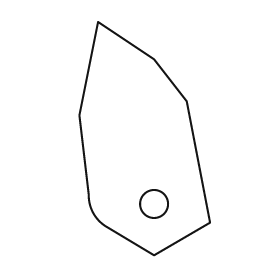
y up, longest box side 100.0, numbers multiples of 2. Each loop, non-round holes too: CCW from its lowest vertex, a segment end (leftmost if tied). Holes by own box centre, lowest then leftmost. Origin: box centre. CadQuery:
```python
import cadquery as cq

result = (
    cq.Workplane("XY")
    .moveTo(4.0, -50.0)
    .lineTo(28.0, -36.0)
    .lineTo(18.0, 16.0)
    .lineTo(4.0, 34.0)
    .lineTo(-20.0, 50.0)
    .lineTo(-28.0, 10.0)
    .lineTo(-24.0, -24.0)
    .threePointArc((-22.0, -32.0), (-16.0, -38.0))
    .close()
    .moveTo(4.0, -28.0)
    .circle(6.0)
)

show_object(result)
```